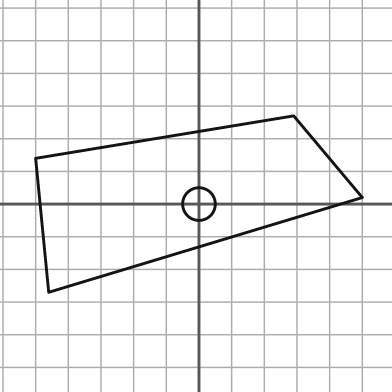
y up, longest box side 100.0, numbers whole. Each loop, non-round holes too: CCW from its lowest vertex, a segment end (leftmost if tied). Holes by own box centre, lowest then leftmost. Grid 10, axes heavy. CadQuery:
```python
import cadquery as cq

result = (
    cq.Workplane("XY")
    .moveTo(-46.0, -27.0)
    .lineTo(50.0, 2.0)
    .lineTo(29.0, 27.0)
    .lineTo(-50.0, 14.0)
    .close()
    .moveTo(0.0, 0.0)
    .circle(5.0)
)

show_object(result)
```